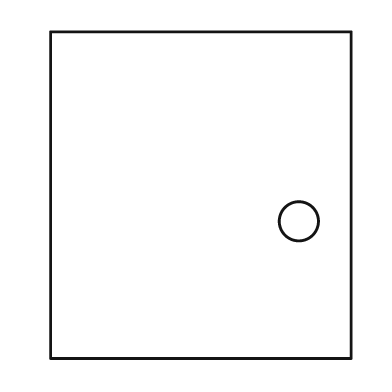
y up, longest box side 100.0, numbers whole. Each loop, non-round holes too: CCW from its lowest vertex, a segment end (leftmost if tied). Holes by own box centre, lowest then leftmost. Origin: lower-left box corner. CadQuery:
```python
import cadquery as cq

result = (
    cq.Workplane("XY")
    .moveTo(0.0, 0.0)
    .lineTo(92.0, 0.0)
    .lineTo(92.0, 100.0)
    .lineTo(0.0, 100.0)
    .close()
    .moveTo(76.0, 42.0)
    .circle(6.0)
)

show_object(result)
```